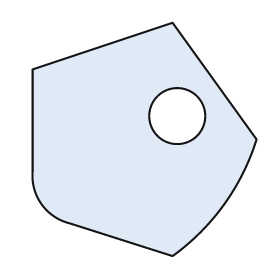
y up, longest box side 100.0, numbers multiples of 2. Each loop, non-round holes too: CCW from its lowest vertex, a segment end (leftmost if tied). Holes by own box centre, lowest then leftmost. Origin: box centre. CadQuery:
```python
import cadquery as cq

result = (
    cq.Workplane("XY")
    .moveTo(12.0, -50.0)
    .threePointArc((34.0, -28.0), (48.0, 0.0))
    .lineTo(12.0, 50.0)
    .lineTo(-48.0, 30.0)
    .lineTo(-48.0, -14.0)
    .threePointArc((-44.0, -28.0), (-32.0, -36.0))
    .close()
    .moveTo(14.0, 10.0)
    .circle(12.0)
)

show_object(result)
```